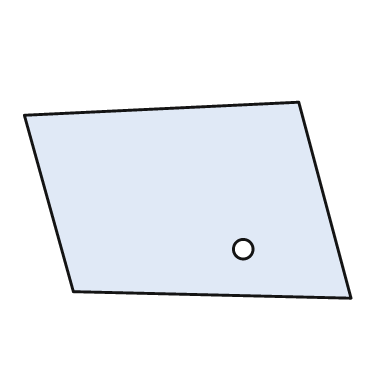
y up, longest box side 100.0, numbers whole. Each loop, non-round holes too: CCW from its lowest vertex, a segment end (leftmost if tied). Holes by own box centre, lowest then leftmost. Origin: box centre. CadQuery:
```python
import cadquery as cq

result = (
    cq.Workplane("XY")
    .moveTo(50.0, -30.0)
    .lineTo(34.0, 30.0)
    .lineTo(-50.0, 26.0)
    .lineTo(-35.0, -28.0)
    .close()
    .moveTo(17.0, -15.0)
    .circle(3.0)
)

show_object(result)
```